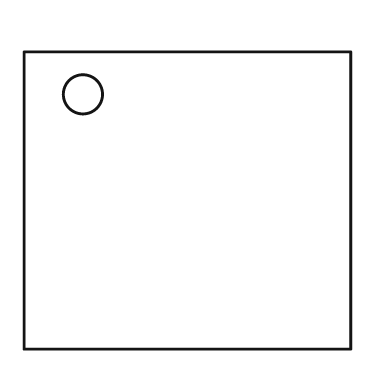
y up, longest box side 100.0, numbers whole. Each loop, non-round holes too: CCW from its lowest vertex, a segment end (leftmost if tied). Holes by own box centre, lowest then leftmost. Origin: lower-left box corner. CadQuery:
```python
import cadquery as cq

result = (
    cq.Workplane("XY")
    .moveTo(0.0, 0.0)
    .lineTo(100.0, 0.0)
    .lineTo(100.0, 91.0)
    .lineTo(0.0, 91.0)
    .close()
    .moveTo(18.0, 78.0)
    .circle(6.0)
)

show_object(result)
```